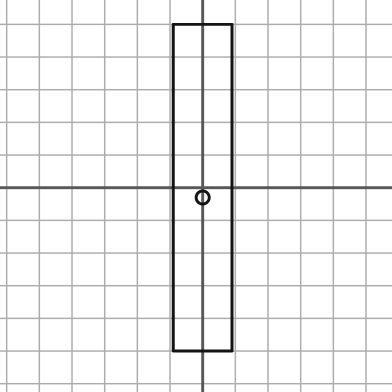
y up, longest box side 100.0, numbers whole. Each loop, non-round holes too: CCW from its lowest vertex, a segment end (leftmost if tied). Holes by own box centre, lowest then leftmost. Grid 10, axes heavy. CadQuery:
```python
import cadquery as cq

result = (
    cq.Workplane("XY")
    .moveTo(-9.0, -50.0)
    .lineTo(9.0, -50.0)
    .lineTo(9.0, 50.0)
    .lineTo(-9.0, 50.0)
    .close()
    .moveTo(0.0, -3.0)
    .circle(2.0)
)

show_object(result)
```